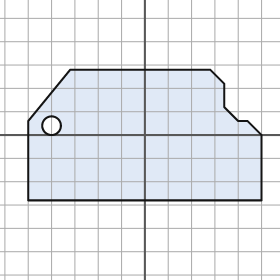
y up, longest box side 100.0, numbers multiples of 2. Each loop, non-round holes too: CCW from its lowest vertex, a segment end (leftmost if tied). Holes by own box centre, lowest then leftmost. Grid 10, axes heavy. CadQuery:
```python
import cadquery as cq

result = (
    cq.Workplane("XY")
    .moveTo(-50.0, -28.0)
    .lineTo(50.0, -28.0)
    .lineTo(50.0, 0.0)
    .lineTo(44.0, 6.0)
    .lineTo(40.0, 6.0)
    .lineTo(34.0, 12.0)
    .lineTo(34.0, 22.0)
    .lineTo(28.0, 28.0)
    .lineTo(-32.0, 28.0)
    .lineTo(-50.0, 6.0)
    .close()
    .moveTo(-40.0, 4.0)
    .circle(4.0)
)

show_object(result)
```